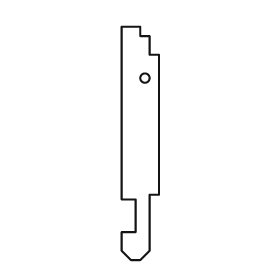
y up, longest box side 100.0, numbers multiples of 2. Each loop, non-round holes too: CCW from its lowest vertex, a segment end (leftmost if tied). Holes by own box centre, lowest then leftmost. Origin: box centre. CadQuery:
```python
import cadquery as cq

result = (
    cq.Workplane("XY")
    .moveTo(-4.0, -50.0)
    .lineTo(0.0, -50.0)
    .lineTo(4.0, -46.0)
    .lineTo(4.0, -22.0)
    .lineTo(8.0, -22.0)
    .lineTo(8.0, 38.0)
    .lineTo(4.0, 38.0)
    .lineTo(4.0, 46.0)
    .lineTo(0.0, 46.0)
    .lineTo(0.0, 50.0)
    .lineTo(-8.0, 50.0)
    .lineTo(-8.0, -24.0)
    .lineTo(-2.0, -24.0)
    .lineTo(-2.0, -38.0)
    .lineTo(-8.0, -38.0)
    .lineTo(-8.0, -46.0)
    .close()
    .moveTo(2.0, 28.0)
    .circle(2.0)
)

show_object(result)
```